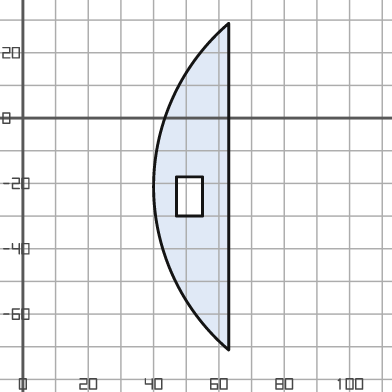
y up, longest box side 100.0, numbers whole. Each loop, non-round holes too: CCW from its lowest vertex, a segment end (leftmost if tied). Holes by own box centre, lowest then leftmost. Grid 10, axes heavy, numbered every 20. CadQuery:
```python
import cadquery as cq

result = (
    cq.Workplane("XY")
    .moveTo(63.0, -71.0)
    .lineTo(63.0, 29.0)
    .threePointArc((40.0, -21.0), (63.0, -71.0))
    .close()
    .moveTo(47.0, -30.0)
    .lineTo(55.0, -30.0)
    .lineTo(55.0, -18.0)
    .lineTo(47.0, -18.0)
    .close()
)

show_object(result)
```